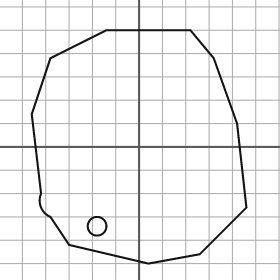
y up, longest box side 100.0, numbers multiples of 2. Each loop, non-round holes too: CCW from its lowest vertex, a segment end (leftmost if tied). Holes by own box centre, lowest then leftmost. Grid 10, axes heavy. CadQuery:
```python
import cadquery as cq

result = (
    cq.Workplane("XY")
    .moveTo(4.0, -50.0)
    .lineTo(26.0, -46.0)
    .lineTo(46.0, -26.0)
    .lineTo(42.0, 10.0)
    .lineTo(32.0, 38.0)
    .lineTo(22.0, 50.0)
    .lineTo(-14.0, 50.0)
    .lineTo(-38.0, 38.0)
    .lineTo(-46.0, 14.0)
    .lineTo(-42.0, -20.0)
    .threePointArc((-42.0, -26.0), (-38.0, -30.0))
    .lineTo(-30.0, -42.0)
    .close()
    .moveTo(-18.0, -34.0)
    .circle(4.0)
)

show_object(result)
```